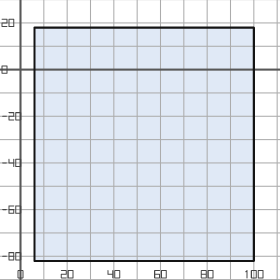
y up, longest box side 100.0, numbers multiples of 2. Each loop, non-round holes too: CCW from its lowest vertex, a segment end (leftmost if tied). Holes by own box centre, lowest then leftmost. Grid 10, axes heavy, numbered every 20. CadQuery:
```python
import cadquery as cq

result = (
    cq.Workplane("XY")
    .moveTo(6.0, -82.0)
    .lineTo(100.0, -82.0)
    .lineTo(100.0, 18.0)
    .lineTo(6.0, 18.0)
    .close()
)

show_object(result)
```